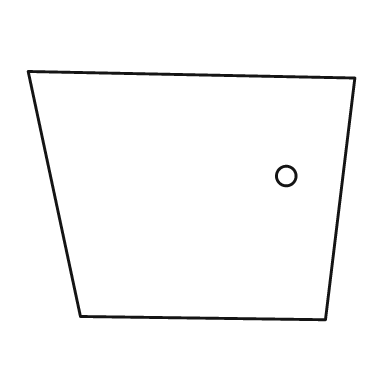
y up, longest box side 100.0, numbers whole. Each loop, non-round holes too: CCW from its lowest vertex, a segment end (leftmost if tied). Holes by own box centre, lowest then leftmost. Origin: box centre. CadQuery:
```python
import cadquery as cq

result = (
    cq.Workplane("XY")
    .moveTo(41.0, -38.0)
    .lineTo(50.0, 36.0)
    .lineTo(-50.0, 38.0)
    .lineTo(-34.0, -37.0)
    .close()
    .moveTo(29.0, 6.0)
    .circle(3.0)
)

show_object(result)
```